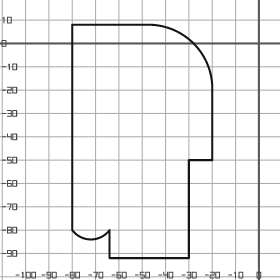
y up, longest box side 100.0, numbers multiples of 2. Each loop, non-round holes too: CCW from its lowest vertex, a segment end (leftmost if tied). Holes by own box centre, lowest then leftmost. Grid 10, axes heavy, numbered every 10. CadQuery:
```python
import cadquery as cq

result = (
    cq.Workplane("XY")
    .moveTo(-64.0, -92.0)
    .lineTo(-30.0, -92.0)
    .lineTo(-30.0, -50.0)
    .lineTo(-20.0, -50.0)
    .lineTo(-20.0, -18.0)
    .threePointArc((-28.0, 0.0), (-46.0, 8.0))
    .lineTo(-80.0, 8.0)
    .lineTo(-80.0, -80.0)
    .threePointArc((-72.0, -84.0), (-64.0, -80.0))
    .close()
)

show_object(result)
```